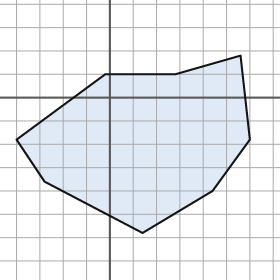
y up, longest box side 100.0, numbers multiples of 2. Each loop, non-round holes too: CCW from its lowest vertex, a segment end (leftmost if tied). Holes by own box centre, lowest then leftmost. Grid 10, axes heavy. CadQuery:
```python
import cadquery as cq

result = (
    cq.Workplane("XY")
    .moveTo(14.0, -58.0)
    .lineTo(44.0, -40.0)
    .lineTo(60.0, -18.0)
    .lineTo(56.0, 18.0)
    .lineTo(28.0, 10.0)
    .lineTo(-2.0, 10.0)
    .lineTo(-40.0, -18.0)
    .lineTo(-28.0, -36.0)
    .close()
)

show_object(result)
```